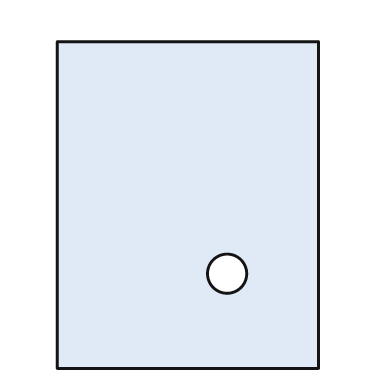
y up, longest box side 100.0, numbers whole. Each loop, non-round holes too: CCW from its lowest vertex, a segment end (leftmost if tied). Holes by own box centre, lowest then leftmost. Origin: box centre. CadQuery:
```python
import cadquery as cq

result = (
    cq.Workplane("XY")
    .moveTo(-40.0, -50.0)
    .lineTo(40.0, -50.0)
    .lineTo(40.0, 50.0)
    .lineTo(-40.0, 50.0)
    .close()
    .moveTo(12.0, -21.0)
    .circle(6.0)
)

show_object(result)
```